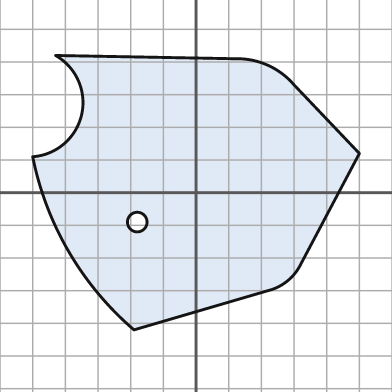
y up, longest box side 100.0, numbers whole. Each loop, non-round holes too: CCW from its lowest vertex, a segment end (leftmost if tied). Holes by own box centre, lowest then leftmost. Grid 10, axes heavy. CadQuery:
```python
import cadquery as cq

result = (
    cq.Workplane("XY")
    .moveTo(-19.0, -42.0)
    .lineTo(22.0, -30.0)
    .threePointArc((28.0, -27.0), (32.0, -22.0))
    .lineTo(50.0, 12.0)
    .lineTo(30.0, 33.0)
    .threePointArc((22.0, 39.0), (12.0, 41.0))
    .lineTo(-43.0, 42.0)
    .threePointArc((-35.0, 24.0), (-50.0, 11.0))
    .threePointArc((-39.0, -18.0), (-19.0, -42.0))
    .close()
    .moveTo(-18.0, -9.0)
    .circle(3.0)
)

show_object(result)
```